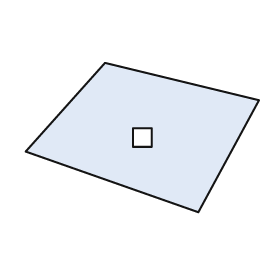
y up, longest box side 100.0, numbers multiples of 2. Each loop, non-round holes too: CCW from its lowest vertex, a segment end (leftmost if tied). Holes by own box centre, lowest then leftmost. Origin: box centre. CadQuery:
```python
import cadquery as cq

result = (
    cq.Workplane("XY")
    .moveTo(24.0, -32.0)
    .lineTo(50.0, 16.0)
    .lineTo(-16.0, 32.0)
    .lineTo(-50.0, -6.0)
    .close()
    .moveTo(-4.0, -4.0)
    .lineTo(4.0, -4.0)
    .lineTo(4.0, 4.0)
    .lineTo(-4.0, 4.0)
    .close()
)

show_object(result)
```